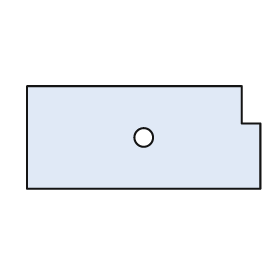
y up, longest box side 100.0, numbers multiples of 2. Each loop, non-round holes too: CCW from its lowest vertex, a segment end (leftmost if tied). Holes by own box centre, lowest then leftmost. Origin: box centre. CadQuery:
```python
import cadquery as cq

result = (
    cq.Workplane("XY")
    .moveTo(-50.0, -22.0)
    .lineTo(50.0, -22.0)
    .lineTo(50.0, 6.0)
    .lineTo(42.0, 6.0)
    .lineTo(42.0, 22.0)
    .lineTo(-50.0, 22.0)
    .close()
    .moveTo(0.0, 0.0)
    .circle(4.0)
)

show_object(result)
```